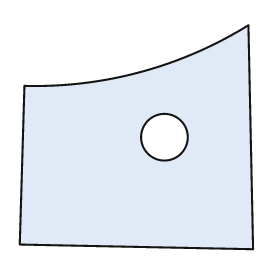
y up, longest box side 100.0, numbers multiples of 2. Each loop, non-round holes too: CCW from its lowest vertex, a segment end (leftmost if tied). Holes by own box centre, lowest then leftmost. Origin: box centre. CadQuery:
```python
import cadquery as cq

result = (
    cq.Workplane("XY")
    .moveTo(50.0, -48.0)
    .lineTo(48.0, 48.0)
    .threePointArc((2.0, 28.0), (-48.0, 22.0))
    .lineTo(-50.0, -46.0)
    .close()
    .moveTo(12.0, 0.0)
    .circle(10.0)
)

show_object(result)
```